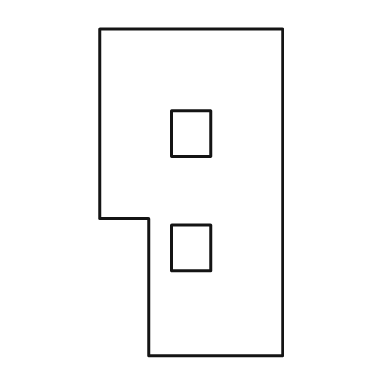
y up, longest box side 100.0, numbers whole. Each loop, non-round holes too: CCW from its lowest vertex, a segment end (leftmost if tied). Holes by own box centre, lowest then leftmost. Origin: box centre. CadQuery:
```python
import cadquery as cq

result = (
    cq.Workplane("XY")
    .moveTo(-13.0, -50.0)
    .lineTo(28.0, -50.0)
    .lineTo(28.0, 50.0)
    .lineTo(-28.0, 50.0)
    .lineTo(-28.0, -8.0)
    .lineTo(-13.0, -8.0)
    .close()
    .moveTo(-6.0, -24.0)
    .lineTo(6.0, -24.0)
    .lineTo(6.0, -10.0)
    .lineTo(-6.0, -10.0)
    .close()
    .moveTo(-6.0, 11.0)
    .lineTo(6.0, 11.0)
    .lineTo(6.0, 25.0)
    .lineTo(-6.0, 25.0)
    .close()
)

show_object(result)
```